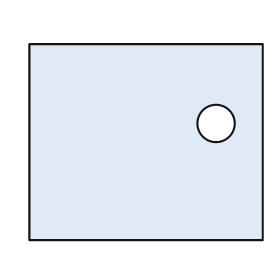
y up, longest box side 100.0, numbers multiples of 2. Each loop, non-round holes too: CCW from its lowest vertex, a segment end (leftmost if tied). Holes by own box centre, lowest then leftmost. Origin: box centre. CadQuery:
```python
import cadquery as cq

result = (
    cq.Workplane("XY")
    .moveTo(-50.0, -42.0)
    .lineTo(50.0, -42.0)
    .lineTo(50.0, 42.0)
    .lineTo(-50.0, 42.0)
    .close()
    .moveTo(30.0, 8.0)
    .circle(8.0)
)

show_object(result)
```